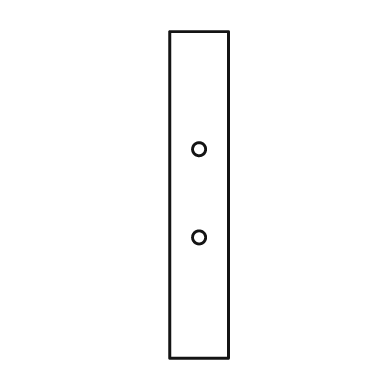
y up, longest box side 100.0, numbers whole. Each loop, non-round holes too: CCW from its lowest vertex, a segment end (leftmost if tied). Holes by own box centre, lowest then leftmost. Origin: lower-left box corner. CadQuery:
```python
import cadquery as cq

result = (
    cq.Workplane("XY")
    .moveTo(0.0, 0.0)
    .lineTo(18.0, 0.0)
    .lineTo(18.0, 100.0)
    .lineTo(0.0, 100.0)
    .close()
    .moveTo(9.0, 37.0)
    .circle(2.0)
    .moveTo(9.0, 64.0)
    .circle(2.0)
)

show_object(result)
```